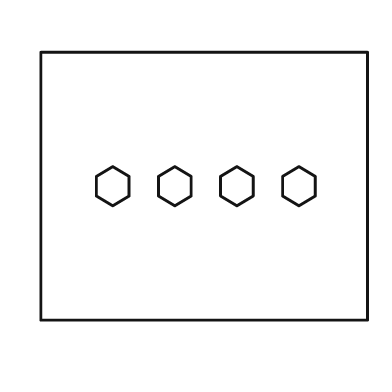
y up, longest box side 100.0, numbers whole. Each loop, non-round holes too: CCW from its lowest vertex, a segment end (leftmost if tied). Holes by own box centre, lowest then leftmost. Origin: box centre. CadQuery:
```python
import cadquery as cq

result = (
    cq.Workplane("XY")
    .moveTo(-50.0, -41.0)
    .lineTo(50.0, -41.0)
    .lineTo(50.0, 41.0)
    .lineTo(-50.0, 41.0)
    .close()
    .moveTo(-28.0, -6.0)
    .lineTo(-23.0, -3.0)
    .lineTo(-23.0, 3.0)
    .lineTo(-28.0, 6.0)
    .lineTo(-33.0, 3.0)
    .lineTo(-33.0, -3.0)
    .close()
    .moveTo(-9.0, -6.0)
    .lineTo(-4.0, -3.0)
    .lineTo(-4.0, 3.0)
    .lineTo(-9.0, 6.0)
    .lineTo(-14.0, 3.0)
    .lineTo(-14.0, -3.0)
    .close()
    .moveTo(10.0, -6.0)
    .lineTo(15.0, -3.0)
    .lineTo(15.0, 3.0)
    .lineTo(10.0, 6.0)
    .lineTo(5.0, 3.0)
    .lineTo(5.0, -3.0)
    .close()
    .moveTo(29.0, -6.0)
    .lineTo(34.0, -3.0)
    .lineTo(34.0, 3.0)
    .lineTo(29.0, 6.0)
    .lineTo(24.0, 3.0)
    .lineTo(24.0, -3.0)
    .close()
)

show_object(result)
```